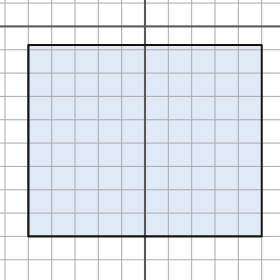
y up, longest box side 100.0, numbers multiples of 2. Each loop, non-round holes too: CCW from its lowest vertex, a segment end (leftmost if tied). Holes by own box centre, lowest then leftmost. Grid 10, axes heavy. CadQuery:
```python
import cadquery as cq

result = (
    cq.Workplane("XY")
    .moveTo(-50.0, -90.0)
    .lineTo(50.0, -90.0)
    .lineTo(50.0, -8.0)
    .lineTo(-50.0, -8.0)
    .close()
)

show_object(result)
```